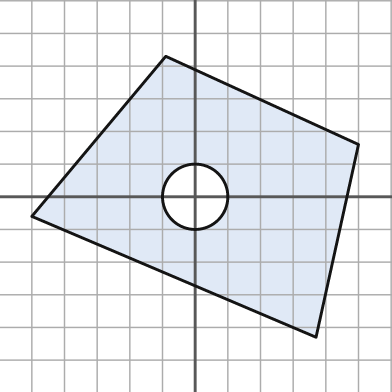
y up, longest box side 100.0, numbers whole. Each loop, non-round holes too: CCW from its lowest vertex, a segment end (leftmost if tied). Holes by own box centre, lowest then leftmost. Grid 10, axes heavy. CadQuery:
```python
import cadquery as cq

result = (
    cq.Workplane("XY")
    .moveTo(37.0, -43.0)
    .lineTo(50.0, 16.0)
    .lineTo(-9.0, 43.0)
    .lineTo(-50.0, -6.0)
    .close()
    .moveTo(0.0, 0.0)
    .circle(10.0)
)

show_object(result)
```